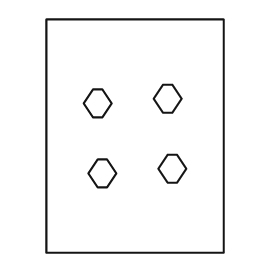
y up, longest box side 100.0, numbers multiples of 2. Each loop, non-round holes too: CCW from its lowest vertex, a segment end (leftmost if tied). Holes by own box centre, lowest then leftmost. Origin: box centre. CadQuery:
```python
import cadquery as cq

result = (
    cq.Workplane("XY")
    .moveTo(-38.0, -50.0)
    .lineTo(38.0, -50.0)
    .lineTo(38.0, 50.0)
    .lineTo(-38.0, 50.0)
    .close()
    .moveTo(-16.0, -22.0)
    .lineTo(-12.0, -22.0)
    .lineTo(-8.0, -16.0)
    .lineTo(-12.0, -10.0)
    .lineTo(-16.0, -10.0)
    .lineTo(-20.0, -16.0)
    .close()
    .moveTo(14.0, -20.0)
    .lineTo(18.0, -20.0)
    .lineTo(22.0, -14.0)
    .lineTo(18.0, -8.0)
    .lineTo(14.0, -8.0)
    .lineTo(10.0, -14.0)
    .close()
    .moveTo(-18.0, 8.0)
    .lineTo(-14.0, 8.0)
    .lineTo(-10.0, 14.0)
    .lineTo(-14.0, 20.0)
    .lineTo(-18.0, 20.0)
    .lineTo(-22.0, 14.0)
    .close()
    .moveTo(12.0, 10.0)
    .lineTo(16.0, 10.0)
    .lineTo(20.0, 16.0)
    .lineTo(16.0, 22.0)
    .lineTo(12.0, 22.0)
    .lineTo(8.0, 16.0)
    .close()
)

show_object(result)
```